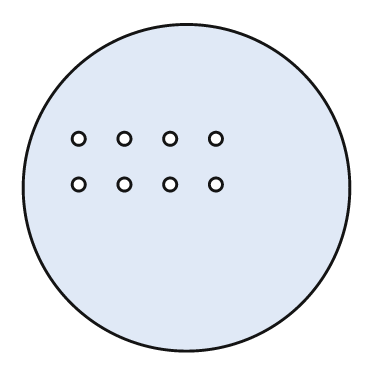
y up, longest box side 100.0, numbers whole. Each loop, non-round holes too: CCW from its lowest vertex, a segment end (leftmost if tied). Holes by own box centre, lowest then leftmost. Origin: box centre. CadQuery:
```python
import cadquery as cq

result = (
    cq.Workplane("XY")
    .moveTo(0.0, 0.0)
    .circle(50.0)
    .moveTo(-33.0, 1.0)
    .circle(2.0)
    .moveTo(-19.0, 1.0)
    .circle(2.0)
    .moveTo(-5.0, 1.0)
    .circle(2.0)
    .moveTo(9.0, 1.0)
    .circle(2.0)
    .moveTo(-33.0, 15.0)
    .circle(2.0)
    .moveTo(-19.0, 15.0)
    .circle(2.0)
    .moveTo(-5.0, 15.0)
    .circle(2.0)
    .moveTo(9.0, 15.0)
    .circle(2.0)
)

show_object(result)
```